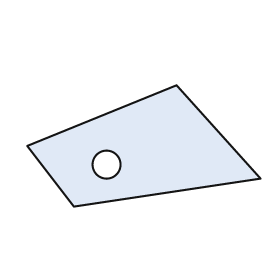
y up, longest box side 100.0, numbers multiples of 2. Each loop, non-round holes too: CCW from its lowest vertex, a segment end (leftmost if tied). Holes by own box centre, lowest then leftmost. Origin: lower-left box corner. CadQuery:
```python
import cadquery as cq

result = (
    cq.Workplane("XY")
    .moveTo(20.0, 0.0)
    .lineTo(100.0, 12.0)
    .lineTo(64.0, 52.0)
    .lineTo(0.0, 26.0)
    .close()
    .moveTo(34.0, 18.0)
    .circle(6.0)
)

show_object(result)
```